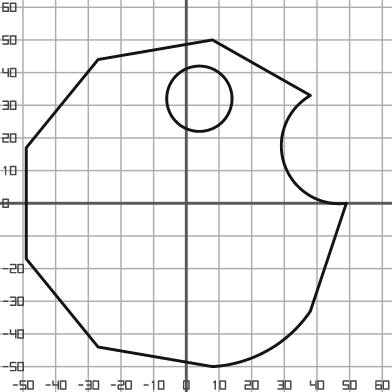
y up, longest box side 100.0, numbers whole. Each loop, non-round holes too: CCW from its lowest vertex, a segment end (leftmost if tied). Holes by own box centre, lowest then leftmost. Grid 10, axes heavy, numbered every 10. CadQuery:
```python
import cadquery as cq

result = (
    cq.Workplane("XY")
    .moveTo(8.0, -50.0)
    .threePointArc((25.0, -45.0), (38.0, -33.0))
    .lineTo(49.0, 0.0)
    .threePointArc((30.0, 12.0), (38.0, 33.0))
    .lineTo(8.0, 50.0)
    .lineTo(-27.0, 44.0)
    .lineTo(-49.0, 17.0)
    .lineTo(-49.0, -17.0)
    .lineTo(-27.0, -44.0)
    .close()
    .moveTo(4.0, 32.0)
    .circle(10.0)
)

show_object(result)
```